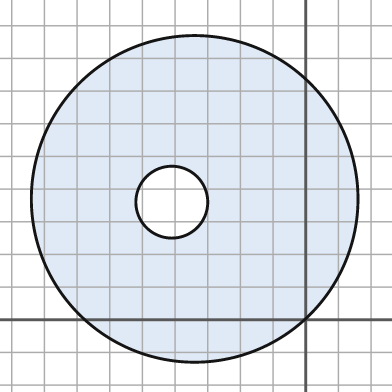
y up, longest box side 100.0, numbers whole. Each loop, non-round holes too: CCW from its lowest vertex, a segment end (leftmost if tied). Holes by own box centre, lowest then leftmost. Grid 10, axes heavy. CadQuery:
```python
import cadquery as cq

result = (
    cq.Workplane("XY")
    .moveTo(-34.0, 37.0)
    .circle(50.0)
    .moveTo(-41.0, 36.0)
    .circle(11.0)
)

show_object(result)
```